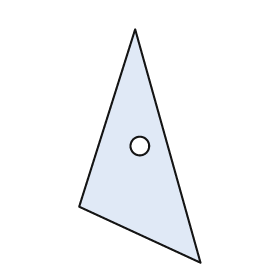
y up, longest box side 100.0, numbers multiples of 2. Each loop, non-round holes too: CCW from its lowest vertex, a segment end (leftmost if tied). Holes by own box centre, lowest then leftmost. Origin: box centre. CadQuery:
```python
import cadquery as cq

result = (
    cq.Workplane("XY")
    .moveTo(26.0, -50.0)
    .lineTo(-2.0, 50.0)
    .lineTo(-26.0, -26.0)
    .close()
    .moveTo(0.0, 0.0)
    .circle(4.0)
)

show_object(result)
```